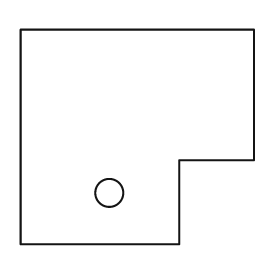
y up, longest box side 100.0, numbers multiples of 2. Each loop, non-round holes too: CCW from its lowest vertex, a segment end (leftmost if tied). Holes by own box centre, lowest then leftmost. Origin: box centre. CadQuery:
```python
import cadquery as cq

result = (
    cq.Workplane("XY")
    .moveTo(-50.0, -46.0)
    .lineTo(18.0, -46.0)
    .lineTo(18.0, -10.0)
    .lineTo(50.0, -10.0)
    .lineTo(50.0, 46.0)
    .lineTo(-50.0, 46.0)
    .close()
    .moveTo(-12.0, -24.0)
    .circle(6.0)
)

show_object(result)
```